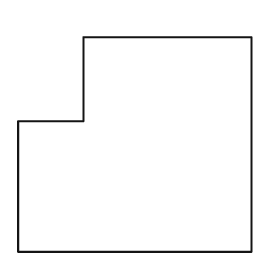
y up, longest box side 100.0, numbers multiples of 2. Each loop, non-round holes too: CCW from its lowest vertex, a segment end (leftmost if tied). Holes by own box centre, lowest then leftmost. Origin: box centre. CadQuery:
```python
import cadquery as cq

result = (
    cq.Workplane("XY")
    .moveTo(-50.0, -46.0)
    .lineTo(50.0, -46.0)
    .lineTo(50.0, 46.0)
    .lineTo(-22.0, 46.0)
    .lineTo(-22.0, 10.0)
    .lineTo(-50.0, 10.0)
    .close()
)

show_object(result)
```